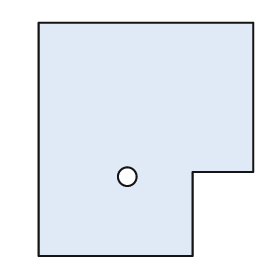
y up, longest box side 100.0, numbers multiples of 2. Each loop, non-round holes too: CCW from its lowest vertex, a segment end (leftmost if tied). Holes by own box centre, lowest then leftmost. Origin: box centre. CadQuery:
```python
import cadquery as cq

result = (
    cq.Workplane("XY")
    .moveTo(-46.0, -50.0)
    .lineTo(20.0, -50.0)
    .lineTo(20.0, -14.0)
    .lineTo(46.0, -14.0)
    .lineTo(46.0, 50.0)
    .lineTo(-46.0, 50.0)
    .close()
    .moveTo(-8.0, -16.0)
    .circle(4.0)
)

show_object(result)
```